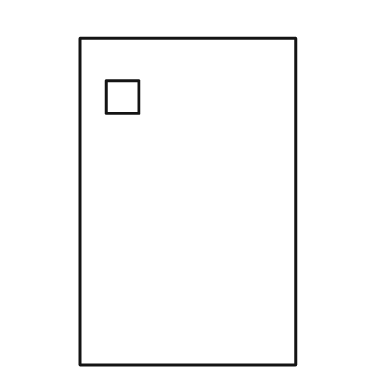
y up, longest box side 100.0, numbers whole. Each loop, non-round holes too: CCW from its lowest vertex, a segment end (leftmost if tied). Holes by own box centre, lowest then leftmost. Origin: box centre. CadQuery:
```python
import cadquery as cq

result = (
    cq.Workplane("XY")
    .moveTo(-33.0, -50.0)
    .lineTo(33.0, -50.0)
    .lineTo(33.0, 50.0)
    .lineTo(-33.0, 50.0)
    .close()
    .moveTo(-25.0, 27.0)
    .lineTo(-15.0, 27.0)
    .lineTo(-15.0, 37.0)
    .lineTo(-25.0, 37.0)
    .close()
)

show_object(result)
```